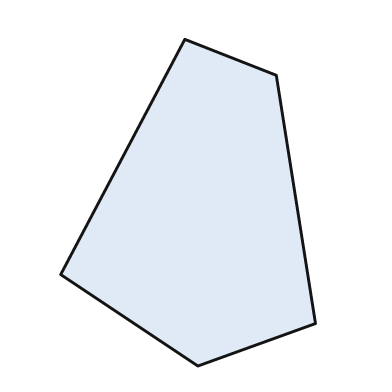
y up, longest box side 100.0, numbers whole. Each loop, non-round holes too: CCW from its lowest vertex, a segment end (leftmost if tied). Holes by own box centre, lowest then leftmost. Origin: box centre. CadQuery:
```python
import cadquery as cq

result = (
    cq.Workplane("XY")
    .moveTo(3.0, -50.0)
    .lineTo(39.0, -37.0)
    .lineTo(27.0, 39.0)
    .lineTo(-1.0, 50.0)
    .lineTo(-39.0, -22.0)
    .close()
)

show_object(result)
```